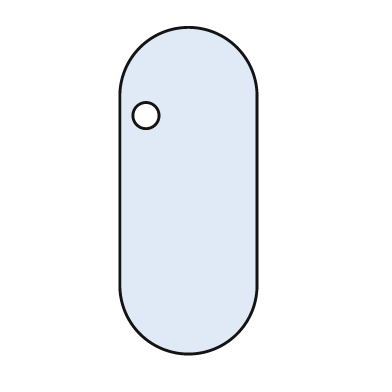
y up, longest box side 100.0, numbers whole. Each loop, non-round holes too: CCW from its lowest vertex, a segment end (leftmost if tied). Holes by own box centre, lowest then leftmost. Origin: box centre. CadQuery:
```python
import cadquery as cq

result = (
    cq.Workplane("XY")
    .moveTo(-21.0, -29.0)
    .threePointArc((0.0, -50.0), (21.0, -29.0))
    .lineTo(21.0, 29.0)
    .threePointArc((0.0, 50.0), (-21.0, 29.0))
    .close()
    .moveTo(-13.0, 23.0)
    .circle(4.0)
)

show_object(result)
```